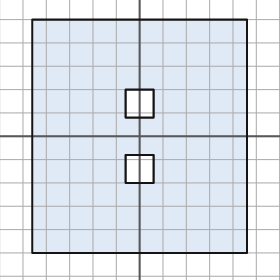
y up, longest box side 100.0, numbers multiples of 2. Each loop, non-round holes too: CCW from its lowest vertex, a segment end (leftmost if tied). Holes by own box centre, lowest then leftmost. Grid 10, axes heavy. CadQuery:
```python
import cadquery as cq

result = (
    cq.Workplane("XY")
    .moveTo(-46.0, -50.0)
    .lineTo(46.0, -50.0)
    .lineTo(46.0, 50.0)
    .lineTo(-46.0, 50.0)
    .close()
    .moveTo(-6.0, -20.0)
    .lineTo(6.0, -20.0)
    .lineTo(6.0, -8.0)
    .lineTo(-6.0, -8.0)
    .close()
    .moveTo(-6.0, 8.0)
    .lineTo(6.0, 8.0)
    .lineTo(6.0, 20.0)
    .lineTo(-6.0, 20.0)
    .close()
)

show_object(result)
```